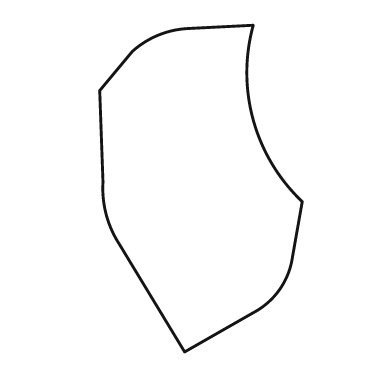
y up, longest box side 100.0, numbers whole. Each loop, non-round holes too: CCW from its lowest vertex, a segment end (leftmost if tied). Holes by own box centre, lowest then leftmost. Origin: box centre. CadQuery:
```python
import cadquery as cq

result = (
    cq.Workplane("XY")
    .moveTo(-5.0, -50.0)
    .lineTo(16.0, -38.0)
    .threePointArc((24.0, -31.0), (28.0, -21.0))
    .lineTo(31.0, -4.0)
    .threePointArc((16.0, 21.0), (16.0, 50.0))
    .lineTo(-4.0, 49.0)
    .threePointArc((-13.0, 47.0), (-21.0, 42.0))
    .lineTo(-31.0, 30.0)
    .lineTo(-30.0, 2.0)
    .threePointArc((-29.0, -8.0), (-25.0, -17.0))
    .close()
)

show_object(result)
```